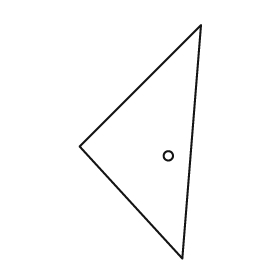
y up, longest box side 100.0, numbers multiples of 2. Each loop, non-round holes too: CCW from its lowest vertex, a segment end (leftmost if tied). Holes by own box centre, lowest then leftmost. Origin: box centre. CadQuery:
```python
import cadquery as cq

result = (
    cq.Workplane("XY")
    .moveTo(18.0, -50.0)
    .lineTo(26.0, 50.0)
    .lineTo(-26.0, -2.0)
    .close()
    .moveTo(12.0, -6.0)
    .circle(2.0)
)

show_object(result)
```